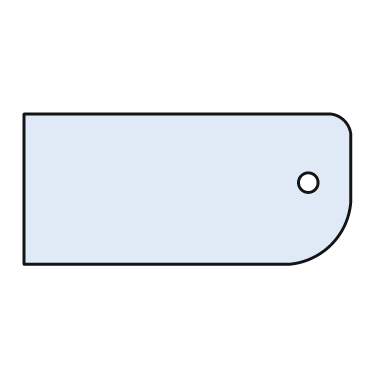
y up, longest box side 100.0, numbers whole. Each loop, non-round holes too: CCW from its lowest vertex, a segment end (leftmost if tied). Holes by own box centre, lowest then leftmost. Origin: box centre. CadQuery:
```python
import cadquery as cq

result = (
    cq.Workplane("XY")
    .moveTo(-50.0, -23.0)
    .lineTo(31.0, -23.0)
    .threePointArc((44.0, -17.0), (50.0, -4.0))
    .lineTo(50.0, 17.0)
    .threePointArc((48.0, 21.0), (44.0, 23.0))
    .lineTo(-50.0, 23.0)
    .close()
    .moveTo(37.0, 2.0)
    .circle(3.0)
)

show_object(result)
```